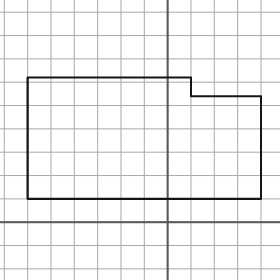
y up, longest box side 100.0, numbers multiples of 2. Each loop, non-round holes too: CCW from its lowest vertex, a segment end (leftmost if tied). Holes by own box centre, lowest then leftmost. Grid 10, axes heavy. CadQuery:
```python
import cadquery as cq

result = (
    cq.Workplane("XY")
    .moveTo(-60.0, 10.0)
    .lineTo(40.0, 10.0)
    .lineTo(40.0, 54.0)
    .lineTo(10.0, 54.0)
    .lineTo(10.0, 62.0)
    .lineTo(-60.0, 62.0)
    .close()
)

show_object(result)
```